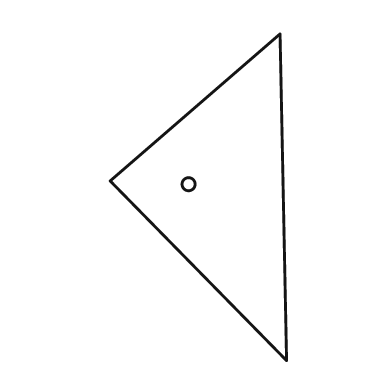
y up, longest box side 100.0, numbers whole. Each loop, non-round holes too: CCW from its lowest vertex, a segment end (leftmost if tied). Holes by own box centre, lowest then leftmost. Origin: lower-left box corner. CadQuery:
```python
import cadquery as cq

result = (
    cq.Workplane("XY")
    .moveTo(54.0, 0.0)
    .lineTo(52.0, 100.0)
    .lineTo(0.0, 55.0)
    .close()
    .moveTo(24.0, 54.0)
    .circle(2.0)
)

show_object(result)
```